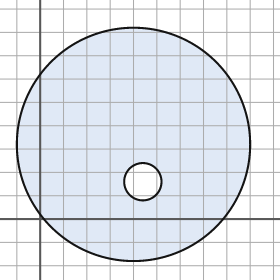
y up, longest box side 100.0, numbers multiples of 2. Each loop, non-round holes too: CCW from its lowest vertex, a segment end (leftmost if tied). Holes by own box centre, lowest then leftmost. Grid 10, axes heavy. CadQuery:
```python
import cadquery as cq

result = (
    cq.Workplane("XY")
    .moveTo(40.0, 32.0)
    .circle(50.0)
    .moveTo(44.0, 16.0)
    .circle(8.0)
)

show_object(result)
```